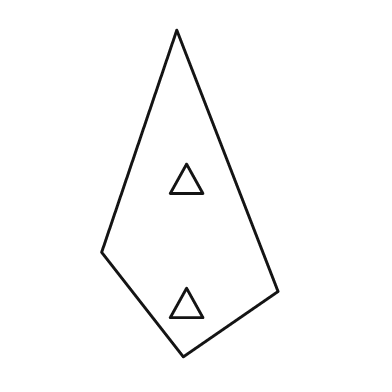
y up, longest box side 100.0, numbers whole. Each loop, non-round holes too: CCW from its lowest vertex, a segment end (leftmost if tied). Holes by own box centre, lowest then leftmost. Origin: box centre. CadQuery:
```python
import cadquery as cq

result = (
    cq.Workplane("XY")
    .moveTo(-2.0, -50.0)
    .lineTo(27.0, -30.0)
    .lineTo(-4.0, 50.0)
    .lineTo(-27.0, -18.0)
    .close()
    .moveTo(-6.0, -38.0)
    .lineTo(4.0, -38.0)
    .lineTo(-1.0, -29.0)
    .close()
    .moveTo(-6.0, 0.0)
    .lineTo(4.0, 0.0)
    .lineTo(-1.0, 9.0)
    .close()
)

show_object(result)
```